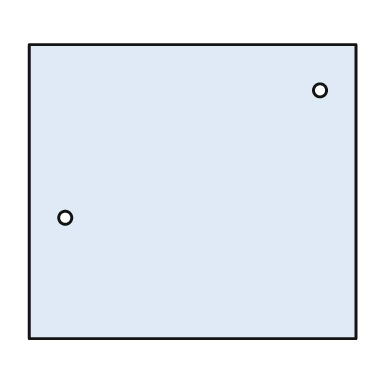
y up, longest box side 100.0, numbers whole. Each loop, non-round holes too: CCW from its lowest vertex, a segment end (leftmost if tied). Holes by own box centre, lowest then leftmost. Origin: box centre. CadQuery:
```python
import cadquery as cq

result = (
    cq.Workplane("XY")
    .moveTo(-50.0, -45.0)
    .lineTo(50.0, -45.0)
    .lineTo(50.0, 45.0)
    .lineTo(-50.0, 45.0)
    .close()
    .moveTo(-39.0, -8.0)
    .circle(2.0)
    .moveTo(39.0, 31.0)
    .circle(2.0)
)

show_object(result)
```